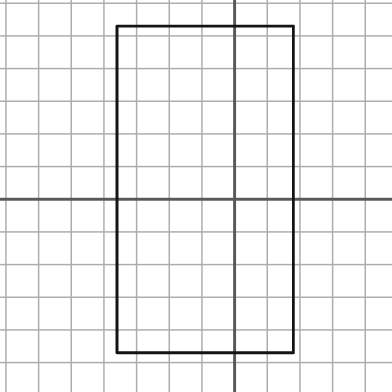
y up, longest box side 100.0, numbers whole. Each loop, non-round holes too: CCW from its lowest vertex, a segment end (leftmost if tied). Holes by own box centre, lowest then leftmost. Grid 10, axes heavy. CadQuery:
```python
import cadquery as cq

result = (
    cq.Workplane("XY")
    .moveTo(-36.0, -47.0)
    .lineTo(18.0, -47.0)
    .lineTo(18.0, 53.0)
    .lineTo(-36.0, 53.0)
    .close()
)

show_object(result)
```